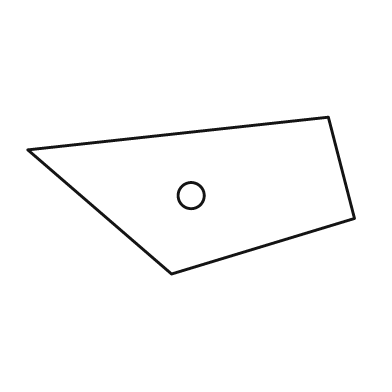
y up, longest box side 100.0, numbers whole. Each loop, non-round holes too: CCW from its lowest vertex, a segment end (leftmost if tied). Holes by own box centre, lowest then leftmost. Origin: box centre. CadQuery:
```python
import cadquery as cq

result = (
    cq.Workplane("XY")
    .moveTo(-6.0, -24.0)
    .lineTo(50.0, -7.0)
    .lineTo(42.0, 24.0)
    .lineTo(-50.0, 14.0)
    .close()
    .moveTo(0.0, 0.0)
    .circle(4.0)
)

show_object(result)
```